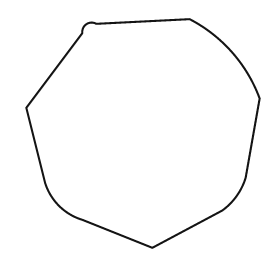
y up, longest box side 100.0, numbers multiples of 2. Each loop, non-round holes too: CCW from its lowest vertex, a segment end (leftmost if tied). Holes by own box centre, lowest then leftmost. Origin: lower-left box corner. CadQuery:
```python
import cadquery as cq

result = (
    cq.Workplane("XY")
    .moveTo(54.0, 0.0)
    .lineTo(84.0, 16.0)
    .threePointArc((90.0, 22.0), (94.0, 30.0))
    .lineTo(100.0, 64.0)
    .threePointArc((88.0, 84.0), (70.0, 98.0))
    .lineTo(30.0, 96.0)
    .threePointArc((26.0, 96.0), (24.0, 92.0))
    .lineTo(0.0, 60.0)
    .lineTo(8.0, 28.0)
    .threePointArc((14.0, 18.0), (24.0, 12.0))
    .close()
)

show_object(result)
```